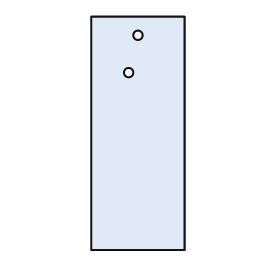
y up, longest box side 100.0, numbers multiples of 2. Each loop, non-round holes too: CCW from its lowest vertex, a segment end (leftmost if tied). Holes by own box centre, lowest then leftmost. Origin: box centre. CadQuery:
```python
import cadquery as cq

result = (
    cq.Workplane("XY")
    .moveTo(-20.0, -50.0)
    .lineTo(20.0, -50.0)
    .lineTo(20.0, 50.0)
    .lineTo(-20.0, 50.0)
    .close()
    .moveTo(-4.0, 26.0)
    .circle(2.0)
    .moveTo(0.0, 42.0)
    .circle(2.0)
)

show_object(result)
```